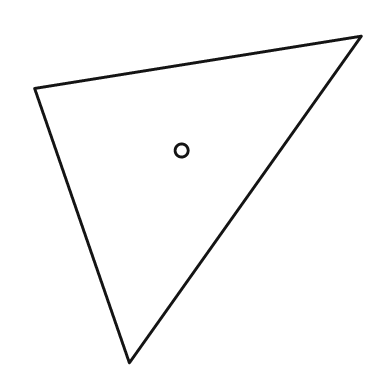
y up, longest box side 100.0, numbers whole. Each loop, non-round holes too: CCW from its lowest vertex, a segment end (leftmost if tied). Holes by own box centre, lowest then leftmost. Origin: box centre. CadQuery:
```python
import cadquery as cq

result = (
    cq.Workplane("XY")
    .moveTo(-21.0, -50.0)
    .lineTo(50.0, 50.0)
    .lineTo(-50.0, 34.0)
    .close()
    .moveTo(-5.0, 15.0)
    .circle(2.0)
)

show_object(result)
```